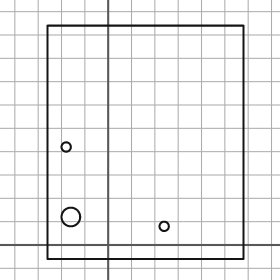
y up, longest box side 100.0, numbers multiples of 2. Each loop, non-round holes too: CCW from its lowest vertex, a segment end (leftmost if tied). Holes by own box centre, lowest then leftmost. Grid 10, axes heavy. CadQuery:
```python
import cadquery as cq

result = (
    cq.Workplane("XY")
    .moveTo(-26.0, -6.0)
    .lineTo(58.0, -6.0)
    .lineTo(58.0, 94.0)
    .lineTo(-26.0, 94.0)
    .close()
    .moveTo(24.0, 8.0)
    .circle(2.0)
    .moveTo(-16.0, 12.0)
    .circle(4.0)
    .moveTo(-18.0, 42.0)
    .circle(2.0)
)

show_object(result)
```